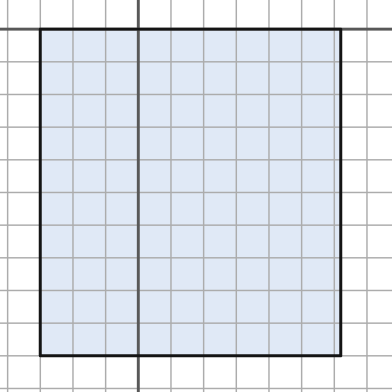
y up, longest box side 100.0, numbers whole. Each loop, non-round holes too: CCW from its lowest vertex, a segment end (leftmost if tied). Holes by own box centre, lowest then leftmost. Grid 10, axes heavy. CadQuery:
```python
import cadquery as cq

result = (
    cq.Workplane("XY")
    .moveTo(-30.0, -100.0)
    .lineTo(62.0, -100.0)
    .lineTo(62.0, 0.0)
    .lineTo(-30.0, 0.0)
    .close()
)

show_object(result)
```